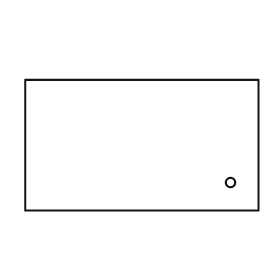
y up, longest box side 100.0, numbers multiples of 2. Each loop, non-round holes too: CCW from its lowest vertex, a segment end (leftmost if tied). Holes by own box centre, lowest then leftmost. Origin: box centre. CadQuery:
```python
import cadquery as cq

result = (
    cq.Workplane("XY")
    .moveTo(-50.0, -28.0)
    .lineTo(50.0, -28.0)
    .lineTo(50.0, 28.0)
    .lineTo(-50.0, 28.0)
    .close()
    .moveTo(38.0, -16.0)
    .circle(2.0)
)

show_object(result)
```